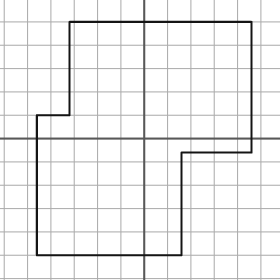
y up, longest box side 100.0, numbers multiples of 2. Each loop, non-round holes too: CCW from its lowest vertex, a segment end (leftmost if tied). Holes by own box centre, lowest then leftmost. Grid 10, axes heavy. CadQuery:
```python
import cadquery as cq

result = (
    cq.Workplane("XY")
    .moveTo(-46.0, -50.0)
    .lineTo(16.0, -50.0)
    .lineTo(16.0, -6.0)
    .lineTo(46.0, -6.0)
    .lineTo(46.0, 50.0)
    .lineTo(-32.0, 50.0)
    .lineTo(-32.0, 10.0)
    .lineTo(-46.0, 10.0)
    .close()
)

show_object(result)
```